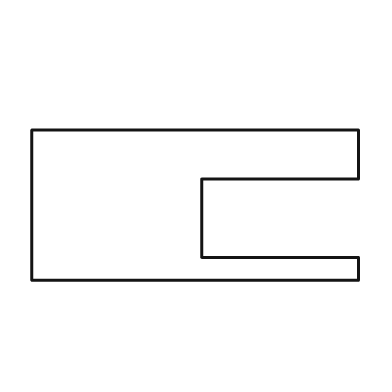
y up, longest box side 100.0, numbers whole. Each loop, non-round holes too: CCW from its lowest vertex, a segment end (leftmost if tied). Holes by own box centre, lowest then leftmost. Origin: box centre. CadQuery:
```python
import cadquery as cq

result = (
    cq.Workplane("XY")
    .moveTo(-50.0, -23.0)
    .lineTo(50.0, -23.0)
    .lineTo(50.0, -16.0)
    .lineTo(2.0, -16.0)
    .lineTo(2.0, 8.0)
    .lineTo(50.0, 8.0)
    .lineTo(50.0, 23.0)
    .lineTo(-50.0, 23.0)
    .close()
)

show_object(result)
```